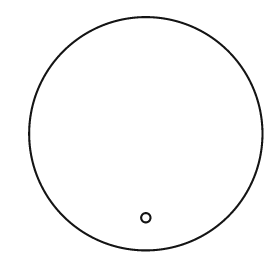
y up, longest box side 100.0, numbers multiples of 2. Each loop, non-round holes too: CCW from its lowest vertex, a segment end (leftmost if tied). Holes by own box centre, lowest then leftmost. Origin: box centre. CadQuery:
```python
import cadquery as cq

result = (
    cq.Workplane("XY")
    .moveTo(0.0, 0.0)
    .circle(50.0)
    .moveTo(0.0, -36.0)
    .circle(2.0)
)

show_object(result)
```